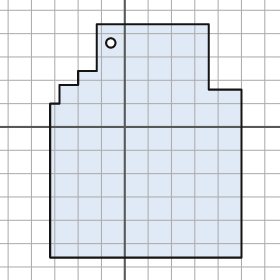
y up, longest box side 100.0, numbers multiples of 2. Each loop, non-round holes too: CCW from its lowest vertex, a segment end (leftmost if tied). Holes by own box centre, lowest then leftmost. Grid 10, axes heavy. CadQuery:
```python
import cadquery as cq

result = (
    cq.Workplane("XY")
    .moveTo(-32.0, -56.0)
    .lineTo(50.0, -56.0)
    .lineTo(50.0, 16.0)
    .lineTo(36.0, 16.0)
    .lineTo(36.0, 44.0)
    .lineTo(-12.0, 44.0)
    .lineTo(-12.0, 24.0)
    .lineTo(-20.0, 24.0)
    .lineTo(-20.0, 18.0)
    .lineTo(-28.0, 18.0)
    .lineTo(-28.0, 10.0)
    .lineTo(-32.0, 10.0)
    .close()
    .moveTo(-6.0, 36.0)
    .circle(2.0)
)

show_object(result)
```